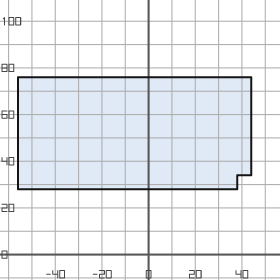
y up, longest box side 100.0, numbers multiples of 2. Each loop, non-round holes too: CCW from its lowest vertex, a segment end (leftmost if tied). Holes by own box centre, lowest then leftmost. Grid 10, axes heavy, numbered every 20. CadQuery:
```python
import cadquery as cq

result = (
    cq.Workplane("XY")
    .moveTo(-56.0, 28.0)
    .lineTo(38.0, 28.0)
    .lineTo(38.0, 34.0)
    .lineTo(44.0, 34.0)
    .lineTo(44.0, 76.0)
    .lineTo(-56.0, 76.0)
    .close()
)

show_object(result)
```